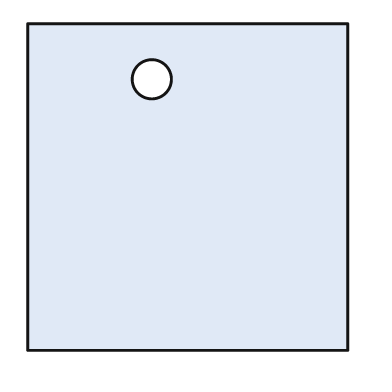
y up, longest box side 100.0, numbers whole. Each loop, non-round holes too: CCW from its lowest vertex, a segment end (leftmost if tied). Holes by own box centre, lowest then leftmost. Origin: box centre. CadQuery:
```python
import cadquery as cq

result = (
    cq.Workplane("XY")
    .moveTo(-49.0, -50.0)
    .lineTo(49.0, -50.0)
    .lineTo(49.0, 50.0)
    .lineTo(-49.0, 50.0)
    .close()
    .moveTo(-11.0, 33.0)
    .circle(6.0)
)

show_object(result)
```